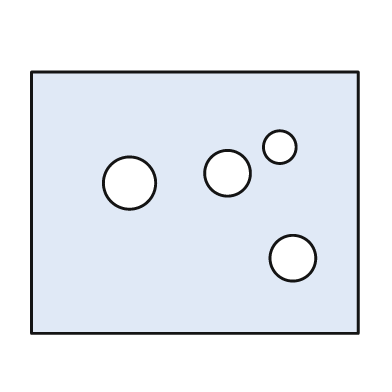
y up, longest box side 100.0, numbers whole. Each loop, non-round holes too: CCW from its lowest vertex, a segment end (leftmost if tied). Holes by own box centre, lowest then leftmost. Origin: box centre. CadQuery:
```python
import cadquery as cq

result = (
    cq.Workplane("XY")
    .moveTo(-50.0, -40.0)
    .lineTo(50.0, -40.0)
    .lineTo(50.0, 40.0)
    .lineTo(-50.0, 40.0)
    .close()
    .moveTo(30.0, -17.0)
    .circle(7.0)
    .moveTo(-20.0, 6.0)
    .circle(8.0)
    .moveTo(10.0, 9.0)
    .circle(7.0)
    .moveTo(26.0, 17.0)
    .circle(5.0)
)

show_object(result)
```